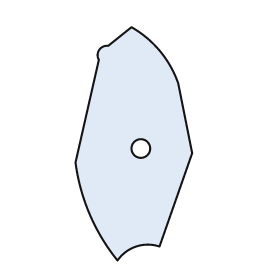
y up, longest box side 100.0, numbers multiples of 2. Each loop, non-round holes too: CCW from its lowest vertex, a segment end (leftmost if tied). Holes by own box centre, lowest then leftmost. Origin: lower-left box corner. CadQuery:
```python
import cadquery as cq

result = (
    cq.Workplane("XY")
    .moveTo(18.0, 0.0)
    .threePointArc((26.0, 6.0), (36.0, 6.0))
    .lineTo(50.0, 46.0)
    .lineTo(44.0, 76.0)
    .threePointArc((36.0, 90.0), (24.0, 100.0))
    .lineTo(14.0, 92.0)
    .threePointArc((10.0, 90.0), (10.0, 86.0))
    .lineTo(0.0, 42.0)
    .threePointArc((6.0, 20.0), (18.0, 0.0))
    .close()
    .moveTo(28.0, 48.0)
    .circle(4.0)
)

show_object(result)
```